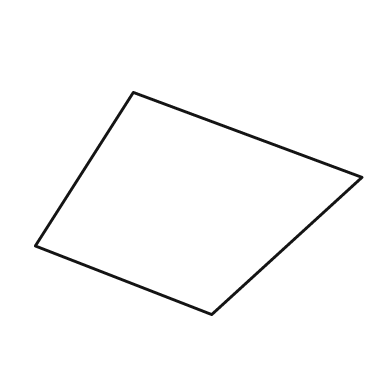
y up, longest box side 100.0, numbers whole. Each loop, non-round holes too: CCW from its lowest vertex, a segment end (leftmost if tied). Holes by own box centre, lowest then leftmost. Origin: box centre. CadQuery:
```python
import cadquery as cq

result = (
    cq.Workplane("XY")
    .moveTo(4.0, -34.0)
    .lineTo(50.0, 8.0)
    .lineTo(-20.0, 34.0)
    .lineTo(-50.0, -13.0)
    .close()
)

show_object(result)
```